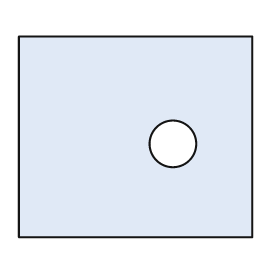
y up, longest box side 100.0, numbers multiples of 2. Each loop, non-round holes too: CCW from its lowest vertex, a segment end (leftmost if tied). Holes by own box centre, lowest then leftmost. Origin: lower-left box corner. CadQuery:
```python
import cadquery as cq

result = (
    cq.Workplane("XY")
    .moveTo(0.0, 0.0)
    .lineTo(100.0, 0.0)
    .lineTo(100.0, 86.0)
    .lineTo(0.0, 86.0)
    .close()
    .moveTo(66.0, 40.0)
    .circle(10.0)
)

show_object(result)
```